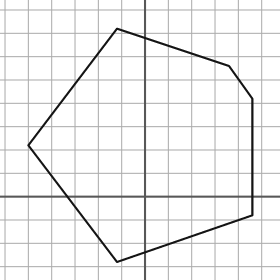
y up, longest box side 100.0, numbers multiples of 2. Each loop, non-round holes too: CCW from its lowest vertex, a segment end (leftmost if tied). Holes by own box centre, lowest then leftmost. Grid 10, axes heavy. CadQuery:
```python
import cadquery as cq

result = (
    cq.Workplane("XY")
    .moveTo(-12.0, -28.0)
    .lineTo(46.0, -8.0)
    .lineTo(46.0, 42.0)
    .lineTo(36.0, 56.0)
    .lineTo(-12.0, 72.0)
    .lineTo(-50.0, 22.0)
    .close()
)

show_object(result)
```